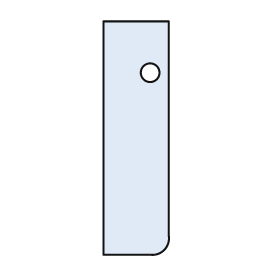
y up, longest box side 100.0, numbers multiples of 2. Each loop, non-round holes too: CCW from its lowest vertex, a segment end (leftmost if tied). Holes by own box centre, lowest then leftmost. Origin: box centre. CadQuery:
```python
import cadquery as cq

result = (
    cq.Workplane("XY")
    .moveTo(-14.0, -50.0)
    .lineTo(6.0, -50.0)
    .threePointArc((12.0, -48.0), (14.0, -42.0))
    .lineTo(14.0, 50.0)
    .lineTo(-14.0, 50.0)
    .close()
    .moveTo(6.0, 28.0)
    .circle(4.0)
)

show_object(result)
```